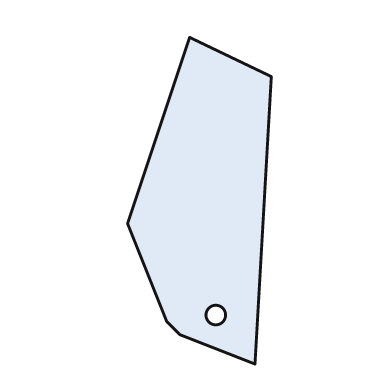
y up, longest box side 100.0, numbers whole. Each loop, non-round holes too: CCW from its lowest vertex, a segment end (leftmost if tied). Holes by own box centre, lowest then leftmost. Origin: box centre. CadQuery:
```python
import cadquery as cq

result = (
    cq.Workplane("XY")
    .moveTo(17.0, -50.0)
    .lineTo(22.0, 38.0)
    .lineTo(-3.0, 50.0)
    .lineTo(-22.0, -7.0)
    .lineTo(-10.0, -37.0)
    .lineTo(-6.0, -41.0)
    .close()
    .moveTo(5.0, -35.0)
    .circle(3.0)
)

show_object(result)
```